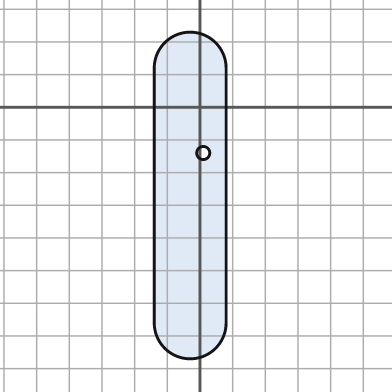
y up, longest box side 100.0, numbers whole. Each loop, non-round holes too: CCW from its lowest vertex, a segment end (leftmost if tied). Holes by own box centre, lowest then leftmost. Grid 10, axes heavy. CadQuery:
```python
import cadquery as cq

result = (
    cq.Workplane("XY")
    .moveTo(-14.0, -66.0)
    .threePointArc((-3.0, -77.0), (8.0, -66.0))
    .lineTo(8.0, 12.0)
    .threePointArc((-3.0, 23.0), (-14.0, 12.0))
    .close()
    .moveTo(1.0, -14.0)
    .circle(2.0)
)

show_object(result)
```